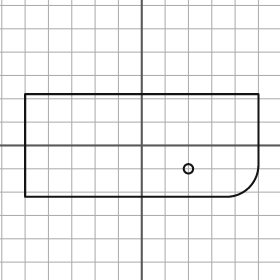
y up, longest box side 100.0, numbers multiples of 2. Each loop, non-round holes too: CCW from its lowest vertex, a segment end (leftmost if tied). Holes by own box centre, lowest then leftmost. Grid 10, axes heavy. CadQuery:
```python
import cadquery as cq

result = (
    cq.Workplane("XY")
    .moveTo(-50.0, -22.0)
    .lineTo(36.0, -22.0)
    .threePointArc((46.0, -18.0), (50.0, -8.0))
    .lineTo(50.0, 22.0)
    .lineTo(-50.0, 22.0)
    .close()
    .moveTo(20.0, -10.0)
    .circle(2.0)
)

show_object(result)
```